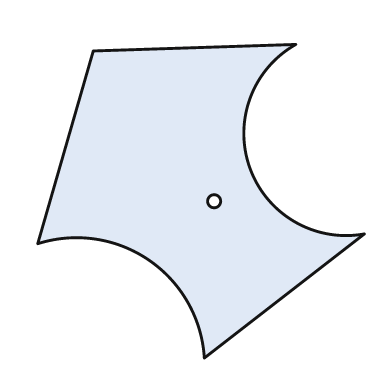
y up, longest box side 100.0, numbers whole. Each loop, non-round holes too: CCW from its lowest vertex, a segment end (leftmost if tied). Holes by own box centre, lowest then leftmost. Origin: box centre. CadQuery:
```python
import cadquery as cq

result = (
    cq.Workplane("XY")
    .moveTo(1.0, -48.0)
    .lineTo(50.0, -10.0)
    .threePointArc((15.0, 10.0), (29.0, 48.0))
    .lineTo(-33.0, 46.0)
    .lineTo(-50.0, -13.0)
    .threePointArc((-16.0, -18.0), (1.0, -48.0))
    .close()
    .moveTo(4.0, 0.0)
    .circle(2.0)
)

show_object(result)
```